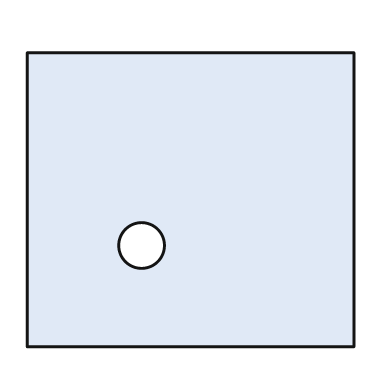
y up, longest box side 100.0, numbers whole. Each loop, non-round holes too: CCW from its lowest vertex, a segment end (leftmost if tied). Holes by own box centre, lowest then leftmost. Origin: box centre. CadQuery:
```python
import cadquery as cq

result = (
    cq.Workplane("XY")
    .moveTo(-50.0, -45.0)
    .lineTo(50.0, -45.0)
    .lineTo(50.0, 45.0)
    .lineTo(-50.0, 45.0)
    .close()
    .moveTo(-15.0, -14.0)
    .circle(7.0)
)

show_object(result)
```